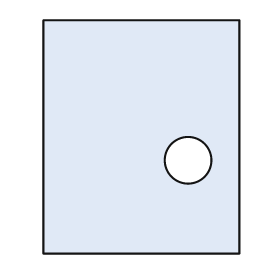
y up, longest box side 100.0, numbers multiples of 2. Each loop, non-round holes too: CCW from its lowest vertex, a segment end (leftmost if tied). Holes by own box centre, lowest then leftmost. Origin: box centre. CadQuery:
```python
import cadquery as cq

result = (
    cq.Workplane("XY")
    .moveTo(-42.0, -50.0)
    .lineTo(42.0, -50.0)
    .lineTo(42.0, 50.0)
    .lineTo(-42.0, 50.0)
    .close()
    .moveTo(20.0, -10.0)
    .circle(10.0)
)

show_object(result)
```